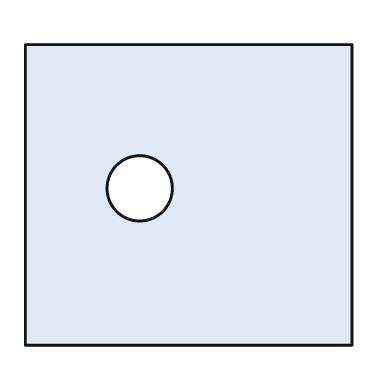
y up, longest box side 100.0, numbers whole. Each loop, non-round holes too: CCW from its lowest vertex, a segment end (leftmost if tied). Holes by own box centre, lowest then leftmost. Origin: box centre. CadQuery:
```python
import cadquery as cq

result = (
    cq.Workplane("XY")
    .moveTo(-50.0, -46.0)
    .lineTo(50.0, -46.0)
    .lineTo(50.0, 46.0)
    .lineTo(-50.0, 46.0)
    .close()
    .moveTo(-15.0, 2.0)
    .circle(10.0)
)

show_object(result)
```